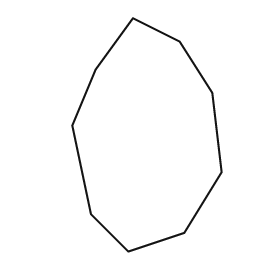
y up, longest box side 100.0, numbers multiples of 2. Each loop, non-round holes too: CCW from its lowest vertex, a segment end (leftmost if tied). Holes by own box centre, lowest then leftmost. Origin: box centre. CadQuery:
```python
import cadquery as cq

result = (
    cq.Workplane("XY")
    .moveTo(-8.0, -50.0)
    .lineTo(16.0, -42.0)
    .lineTo(32.0, -16.0)
    .lineTo(28.0, 18.0)
    .lineTo(14.0, 40.0)
    .lineTo(-6.0, 50.0)
    .lineTo(-22.0, 28.0)
    .lineTo(-32.0, 4.0)
    .lineTo(-24.0, -34.0)
    .close()
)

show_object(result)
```